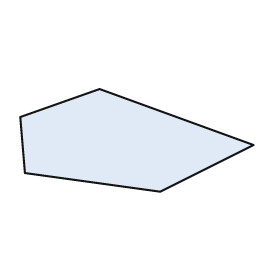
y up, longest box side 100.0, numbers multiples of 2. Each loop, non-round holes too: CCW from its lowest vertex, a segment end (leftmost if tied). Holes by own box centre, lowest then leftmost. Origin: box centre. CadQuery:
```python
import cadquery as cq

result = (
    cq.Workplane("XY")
    .moveTo(10.0, -22.0)
    .lineTo(50.0, -2.0)
    .lineTo(-16.0, 22.0)
    .lineTo(-50.0, 10.0)
    .lineTo(-48.0, -14.0)
    .close()
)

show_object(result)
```